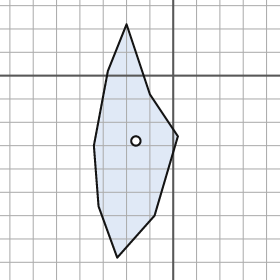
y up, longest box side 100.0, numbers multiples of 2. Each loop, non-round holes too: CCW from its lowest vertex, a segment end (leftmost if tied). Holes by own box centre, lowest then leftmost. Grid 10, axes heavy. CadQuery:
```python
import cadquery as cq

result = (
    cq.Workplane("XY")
    .moveTo(-24.0, -78.0)
    .lineTo(-8.0, -60.0)
    .lineTo(2.0, -26.0)
    .lineTo(-10.0, -8.0)
    .lineTo(-20.0, 22.0)
    .lineTo(-28.0, 2.0)
    .lineTo(-34.0, -30.0)
    .lineTo(-32.0, -56.0)
    .close()
    .moveTo(-16.0, -28.0)
    .circle(2.0)
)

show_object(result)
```